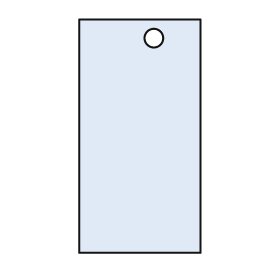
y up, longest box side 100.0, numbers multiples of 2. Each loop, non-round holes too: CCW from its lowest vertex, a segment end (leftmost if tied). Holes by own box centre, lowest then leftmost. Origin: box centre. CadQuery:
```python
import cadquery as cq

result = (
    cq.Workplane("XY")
    .moveTo(-26.0, -50.0)
    .lineTo(26.0, -50.0)
    .lineTo(26.0, 50.0)
    .lineTo(-26.0, 50.0)
    .close()
    .moveTo(6.0, 42.0)
    .circle(4.0)
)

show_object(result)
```